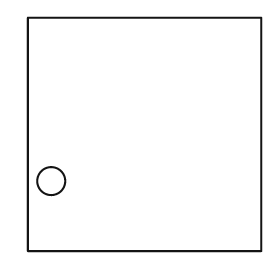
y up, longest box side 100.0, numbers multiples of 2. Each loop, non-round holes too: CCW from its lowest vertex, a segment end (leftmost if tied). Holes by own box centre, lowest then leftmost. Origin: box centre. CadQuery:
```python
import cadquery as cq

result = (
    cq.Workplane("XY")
    .moveTo(-50.0, -50.0)
    .lineTo(50.0, -50.0)
    .lineTo(50.0, 50.0)
    .lineTo(-50.0, 50.0)
    .close()
    .moveTo(-40.0, -20.0)
    .circle(6.0)
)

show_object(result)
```